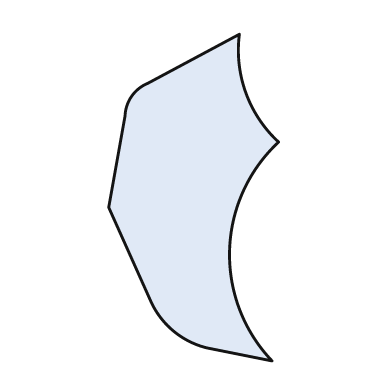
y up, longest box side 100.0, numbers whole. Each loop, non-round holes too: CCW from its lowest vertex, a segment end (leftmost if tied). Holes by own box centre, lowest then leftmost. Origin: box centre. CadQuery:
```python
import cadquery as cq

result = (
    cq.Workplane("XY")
    .moveTo(24.0, -50.0)
    .threePointArc((11.0, -16.0), (26.0, 17.0))
    .threePointArc((16.0, 32.0), (14.0, 50.0))
    .lineTo(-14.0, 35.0)
    .threePointArc((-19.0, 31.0), (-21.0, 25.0))
    .lineTo(-26.0, -3.0)
    .lineTo(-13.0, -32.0)
    .threePointArc((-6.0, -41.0), (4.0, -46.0))
    .close()
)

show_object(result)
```